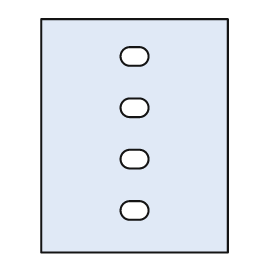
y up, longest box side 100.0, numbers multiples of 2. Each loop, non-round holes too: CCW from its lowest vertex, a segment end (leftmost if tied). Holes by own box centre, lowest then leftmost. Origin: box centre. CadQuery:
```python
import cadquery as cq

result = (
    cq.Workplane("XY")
    .moveTo(-40.0, -50.0)
    .lineTo(40.0, -50.0)
    .lineTo(40.0, 50.0)
    .lineTo(-40.0, 50.0)
    .close()
    .moveTo(-2.0, -36.0)
    .lineTo(2.0, -36.0)
    .threePointArc((6.0, -32.0), (2.0, -28.0))
    .lineTo(-2.0, -28.0)
    .threePointArc((-6.0, -32.0), (-2.0, -36.0))
    .close()
    .moveTo(-2.0, -14.0)
    .lineTo(2.0, -14.0)
    .threePointArc((6.0, -10.0), (2.0, -6.0))
    .lineTo(-2.0, -6.0)
    .threePointArc((-6.0, -10.0), (-2.0, -14.0))
    .close()
    .moveTo(-2.0, 8.0)
    .lineTo(2.0, 8.0)
    .threePointArc((6.0, 12.0), (2.0, 16.0))
    .lineTo(-2.0, 16.0)
    .threePointArc((-6.0, 12.0), (-2.0, 8.0))
    .close()
    .moveTo(-2.0, 30.0)
    .lineTo(2.0, 30.0)
    .threePointArc((6.0, 34.0), (2.0, 38.0))
    .lineTo(-2.0, 38.0)
    .threePointArc((-6.0, 34.0), (-2.0, 30.0))
    .close()
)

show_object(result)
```